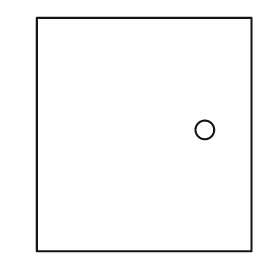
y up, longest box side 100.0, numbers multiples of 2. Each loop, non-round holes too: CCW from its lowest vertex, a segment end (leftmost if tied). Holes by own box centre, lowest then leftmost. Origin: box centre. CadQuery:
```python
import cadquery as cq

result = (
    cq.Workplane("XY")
    .moveTo(-46.0, -50.0)
    .lineTo(46.0, -50.0)
    .lineTo(46.0, 50.0)
    .lineTo(-46.0, 50.0)
    .close()
    .moveTo(26.0, 2.0)
    .circle(4.0)
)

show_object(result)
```